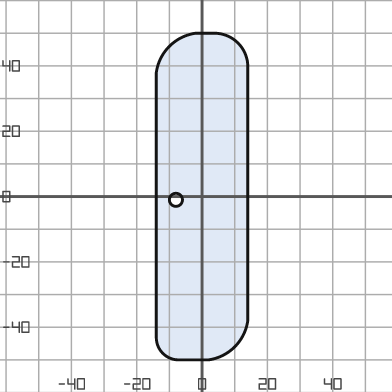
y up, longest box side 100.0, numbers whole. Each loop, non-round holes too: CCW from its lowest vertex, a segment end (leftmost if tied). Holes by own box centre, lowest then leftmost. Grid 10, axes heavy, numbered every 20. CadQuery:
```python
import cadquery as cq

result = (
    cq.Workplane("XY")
    .moveTo(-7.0, -50.0)
    .lineTo(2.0, -50.0)
    .threePointArc((10.0, -46.0), (14.0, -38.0))
    .lineTo(14.0, 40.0)
    .threePointArc((11.0, 47.0), (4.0, 50.0))
    .lineTo(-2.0, 50.0)
    .threePointArc((-10.0, 46.0), (-14.0, 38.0))
    .lineTo(-14.0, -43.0)
    .threePointArc((-12.0, -48.0), (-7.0, -50.0))
    .close()
    .moveTo(-8.0, -1.0)
    .circle(2.0)
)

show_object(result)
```